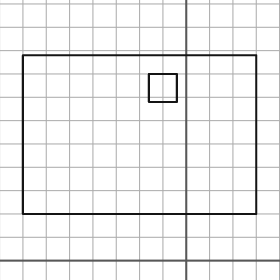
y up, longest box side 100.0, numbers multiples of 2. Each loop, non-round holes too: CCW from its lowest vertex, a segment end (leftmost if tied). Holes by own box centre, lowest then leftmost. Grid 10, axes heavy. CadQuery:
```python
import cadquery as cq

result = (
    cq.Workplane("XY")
    .moveTo(-70.0, 20.0)
    .lineTo(30.0, 20.0)
    .lineTo(30.0, 88.0)
    .lineTo(-70.0, 88.0)
    .close()
    .moveTo(-16.0, 68.0)
    .lineTo(-4.0, 68.0)
    .lineTo(-4.0, 80.0)
    .lineTo(-16.0, 80.0)
    .close()
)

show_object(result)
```